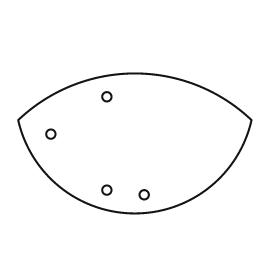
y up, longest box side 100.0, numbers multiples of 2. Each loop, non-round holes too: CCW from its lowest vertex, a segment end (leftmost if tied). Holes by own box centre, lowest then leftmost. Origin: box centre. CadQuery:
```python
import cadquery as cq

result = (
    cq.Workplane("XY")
    .moveTo(-50.0, 10.0)
    .threePointArc((0.0, -30.0), (50.0, 10.0))
    .threePointArc((0.0, 30.0), (-50.0, 10.0))
    .close()
    .moveTo(4.0, -22.0)
    .circle(2.0)
    .moveTo(-12.0, -20.0)
    .circle(2.0)
    .moveTo(-36.0, 4.0)
    .circle(2.0)
    .moveTo(-12.0, 20.0)
    .circle(2.0)
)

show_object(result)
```